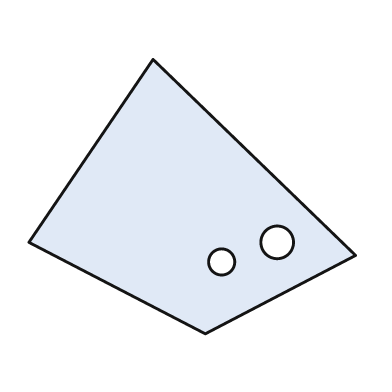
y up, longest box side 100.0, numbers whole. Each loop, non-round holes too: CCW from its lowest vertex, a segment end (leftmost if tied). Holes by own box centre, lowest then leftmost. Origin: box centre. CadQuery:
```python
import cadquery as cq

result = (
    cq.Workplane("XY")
    .moveTo(4.0, -42.0)
    .lineTo(50.0, -18.0)
    .lineTo(-12.0, 42.0)
    .lineTo(-50.0, -14.0)
    .close()
    .moveTo(9.0, -20.0)
    .circle(4.0)
    .moveTo(26.0, -14.0)
    .circle(5.0)
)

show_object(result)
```